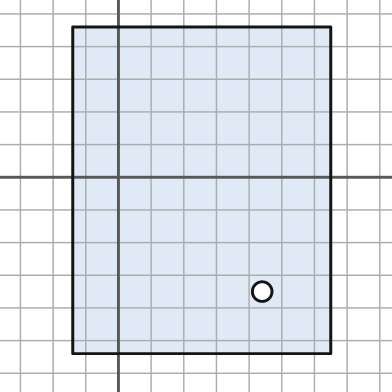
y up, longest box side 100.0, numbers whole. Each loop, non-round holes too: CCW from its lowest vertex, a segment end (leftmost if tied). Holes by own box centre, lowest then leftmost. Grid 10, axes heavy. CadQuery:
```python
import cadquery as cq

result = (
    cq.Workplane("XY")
    .moveTo(-14.0, -54.0)
    .lineTo(65.0, -54.0)
    .lineTo(65.0, 46.0)
    .lineTo(-14.0, 46.0)
    .close()
    .moveTo(44.0, -35.0)
    .circle(3.0)
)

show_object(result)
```